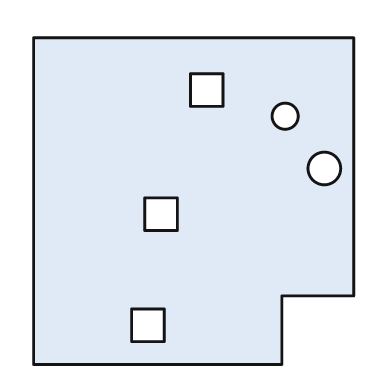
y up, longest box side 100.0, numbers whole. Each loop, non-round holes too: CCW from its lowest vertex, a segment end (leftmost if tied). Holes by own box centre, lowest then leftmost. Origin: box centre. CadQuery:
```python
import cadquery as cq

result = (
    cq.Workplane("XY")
    .moveTo(-49.0, -50.0)
    .lineTo(27.0, -50.0)
    .lineTo(27.0, -29.0)
    .lineTo(49.0, -29.0)
    .lineTo(49.0, 50.0)
    .lineTo(-49.0, 50.0)
    .close()
    .moveTo(-19.0, -43.0)
    .lineTo(-9.0, -43.0)
    .lineTo(-9.0, -33.0)
    .lineTo(-19.0, -33.0)
    .close()
    .moveTo(-15.0, -9.0)
    .lineTo(-5.0, -9.0)
    .lineTo(-5.0, 1.0)
    .lineTo(-15.0, 1.0)
    .close()
    .moveTo(40.0, 10.0)
    .circle(5.0)
    .moveTo(28.0, 26.0)
    .circle(4.0)
    .moveTo(-1.0, 29.0)
    .lineTo(9.0, 29.0)
    .lineTo(9.0, 39.0)
    .lineTo(-1.0, 39.0)
    .close()
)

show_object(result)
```